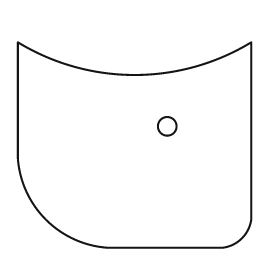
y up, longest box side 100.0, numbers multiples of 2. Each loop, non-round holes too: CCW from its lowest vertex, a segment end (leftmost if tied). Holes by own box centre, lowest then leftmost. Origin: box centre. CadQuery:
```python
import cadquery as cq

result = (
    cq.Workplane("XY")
    .moveTo(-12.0, -44.0)
    .lineTo(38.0, -44.0)
    .threePointArc((46.0, -40.0), (50.0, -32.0))
    .lineTo(50.0, 44.0)
    .threePointArc((0.0, 30.0), (-50.0, 44.0))
    .lineTo(-50.0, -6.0)
    .threePointArc((-38.0, -32.0), (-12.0, -44.0))
    .close()
    .moveTo(14.0, 8.0)
    .circle(4.0)
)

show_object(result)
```